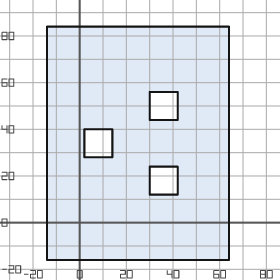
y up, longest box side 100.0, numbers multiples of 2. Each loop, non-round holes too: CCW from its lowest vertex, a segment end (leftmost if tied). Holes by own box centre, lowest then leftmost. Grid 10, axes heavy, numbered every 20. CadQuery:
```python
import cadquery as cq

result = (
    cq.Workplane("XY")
    .moveTo(-14.0, -16.0)
    .lineTo(64.0, -16.0)
    .lineTo(64.0, 84.0)
    .lineTo(-14.0, 84.0)
    .close()
    .moveTo(30.0, 12.0)
    .lineTo(42.0, 12.0)
    .lineTo(42.0, 24.0)
    .lineTo(30.0, 24.0)
    .close()
    .moveTo(2.0, 28.0)
    .lineTo(14.0, 28.0)
    .lineTo(14.0, 40.0)
    .lineTo(2.0, 40.0)
    .close()
    .moveTo(30.0, 44.0)
    .lineTo(42.0, 44.0)
    .lineTo(42.0, 56.0)
    .lineTo(30.0, 56.0)
    .close()
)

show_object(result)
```